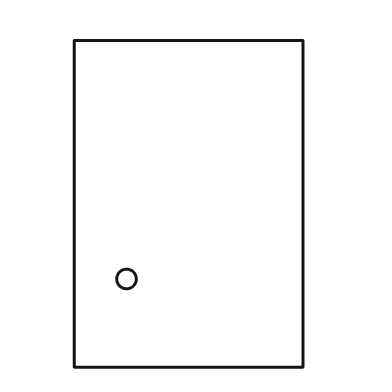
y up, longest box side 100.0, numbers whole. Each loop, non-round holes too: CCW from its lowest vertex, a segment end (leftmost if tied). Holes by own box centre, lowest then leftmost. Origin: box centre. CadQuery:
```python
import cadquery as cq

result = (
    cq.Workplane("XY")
    .moveTo(-35.0, -50.0)
    .lineTo(35.0, -50.0)
    .lineTo(35.0, 50.0)
    .lineTo(-35.0, 50.0)
    .close()
    .moveTo(-19.0, -23.0)
    .circle(3.0)
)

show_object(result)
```